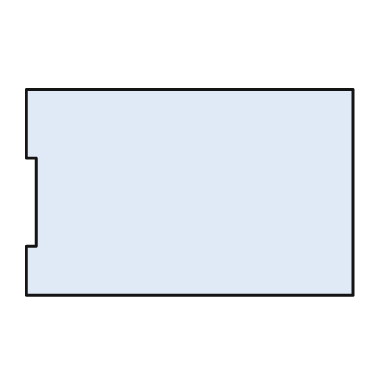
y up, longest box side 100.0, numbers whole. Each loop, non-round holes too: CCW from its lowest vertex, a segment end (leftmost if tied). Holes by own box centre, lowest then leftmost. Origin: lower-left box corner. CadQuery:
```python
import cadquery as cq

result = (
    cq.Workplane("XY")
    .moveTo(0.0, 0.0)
    .lineTo(100.0, 0.0)
    .lineTo(100.0, 63.0)
    .lineTo(0.0, 63.0)
    .lineTo(0.0, 42.0)
    .lineTo(3.0, 42.0)
    .lineTo(3.0, 15.0)
    .lineTo(0.0, 15.0)
    .close()
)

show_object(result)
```